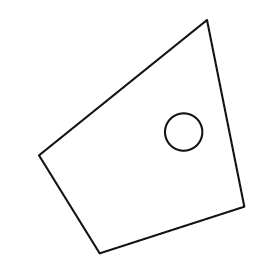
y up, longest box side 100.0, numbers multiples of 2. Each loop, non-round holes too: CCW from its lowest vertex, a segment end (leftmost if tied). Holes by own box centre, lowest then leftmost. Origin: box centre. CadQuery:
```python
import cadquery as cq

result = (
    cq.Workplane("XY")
    .moveTo(-18.0, -50.0)
    .lineTo(44.0, -30.0)
    .lineTo(28.0, 50.0)
    .lineTo(-44.0, -8.0)
    .close()
    .moveTo(18.0, 2.0)
    .circle(8.0)
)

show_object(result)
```